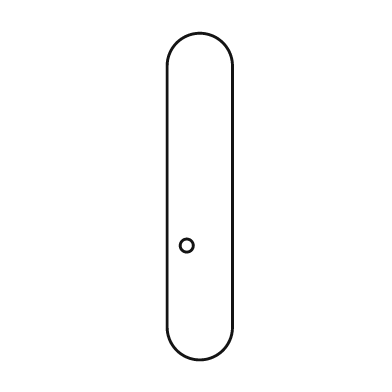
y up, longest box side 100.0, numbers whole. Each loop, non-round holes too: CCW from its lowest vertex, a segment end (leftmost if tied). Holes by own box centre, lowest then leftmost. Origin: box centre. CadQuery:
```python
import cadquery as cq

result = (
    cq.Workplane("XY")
    .moveTo(-10.0, -40.0)
    .threePointArc((0.0, -50.0), (10.0, -40.0))
    .lineTo(10.0, 40.0)
    .threePointArc((0.0, 50.0), (-10.0, 40.0))
    .close()
    .moveTo(-4.0, -15.0)
    .circle(2.0)
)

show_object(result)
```